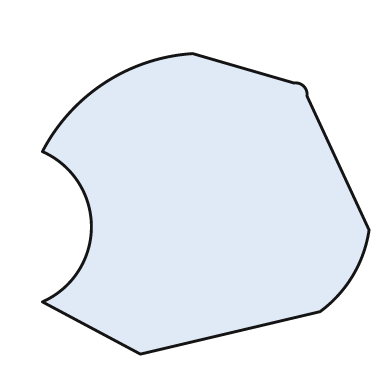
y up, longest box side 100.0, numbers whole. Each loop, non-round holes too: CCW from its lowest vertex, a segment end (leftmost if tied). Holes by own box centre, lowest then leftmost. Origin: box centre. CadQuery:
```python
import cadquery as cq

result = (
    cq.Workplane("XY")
    .moveTo(-20.0, -46.0)
    .lineTo(35.0, -33.0)
    .threePointArc((45.0, -22.0), (50.0, -8.0))
    .lineTo(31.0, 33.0)
    .threePointArc((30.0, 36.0), (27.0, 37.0))
    .lineTo(-4.0, 46.0)
    .threePointArc((-31.0, 37.0), (-50.0, 16.0))
    .threePointArc((-35.0, -7.0), (-50.0, -30.0))
    .close()
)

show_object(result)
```